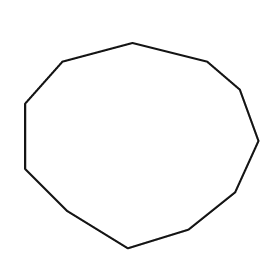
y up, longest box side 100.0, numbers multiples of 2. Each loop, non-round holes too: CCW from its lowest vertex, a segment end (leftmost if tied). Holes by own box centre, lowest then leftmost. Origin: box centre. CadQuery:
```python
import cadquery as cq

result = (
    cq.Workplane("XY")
    .moveTo(-6.0, -44.0)
    .lineTo(20.0, -36.0)
    .lineTo(40.0, -20.0)
    .lineTo(50.0, 2.0)
    .lineTo(42.0, 24.0)
    .lineTo(28.0, 36.0)
    .lineTo(-4.0, 44.0)
    .lineTo(-34.0, 36.0)
    .lineTo(-50.0, 18.0)
    .lineTo(-50.0, -10.0)
    .lineTo(-32.0, -28.0)
    .close()
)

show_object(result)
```